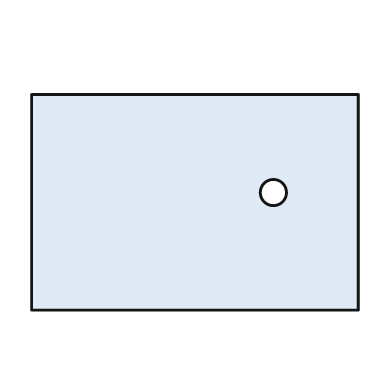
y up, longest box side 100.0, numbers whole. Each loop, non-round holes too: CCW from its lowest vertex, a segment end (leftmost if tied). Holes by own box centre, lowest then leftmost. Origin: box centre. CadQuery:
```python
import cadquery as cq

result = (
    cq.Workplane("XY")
    .moveTo(-50.0, -33.0)
    .lineTo(50.0, -33.0)
    .lineTo(50.0, 33.0)
    .lineTo(-50.0, 33.0)
    .close()
    .moveTo(24.0, 3.0)
    .circle(4.0)
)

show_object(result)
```